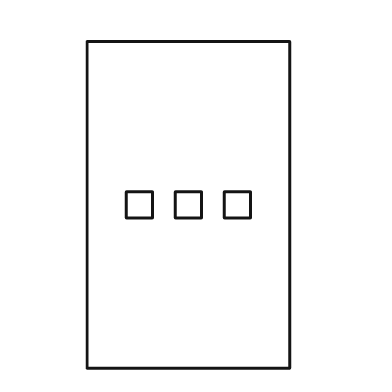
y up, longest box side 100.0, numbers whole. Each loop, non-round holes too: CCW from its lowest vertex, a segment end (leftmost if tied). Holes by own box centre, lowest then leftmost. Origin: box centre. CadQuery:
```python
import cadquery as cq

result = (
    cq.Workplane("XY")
    .moveTo(-31.0, -50.0)
    .lineTo(31.0, -50.0)
    .lineTo(31.0, 50.0)
    .lineTo(-31.0, 50.0)
    .close()
    .moveTo(-19.0, -4.0)
    .lineTo(-11.0, -4.0)
    .lineTo(-11.0, 4.0)
    .lineTo(-19.0, 4.0)
    .close()
    .moveTo(-4.0, -4.0)
    .lineTo(4.0, -4.0)
    .lineTo(4.0, 4.0)
    .lineTo(-4.0, 4.0)
    .close()
    .moveTo(11.0, -4.0)
    .lineTo(19.0, -4.0)
    .lineTo(19.0, 4.0)
    .lineTo(11.0, 4.0)
    .close()
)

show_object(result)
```